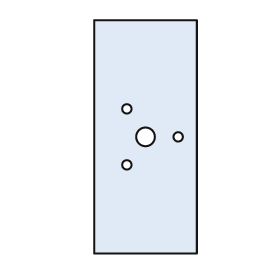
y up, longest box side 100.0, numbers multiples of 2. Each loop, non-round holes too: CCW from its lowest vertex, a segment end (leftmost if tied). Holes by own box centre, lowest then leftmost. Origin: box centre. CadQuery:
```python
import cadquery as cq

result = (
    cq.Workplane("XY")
    .moveTo(-22.0, -50.0)
    .lineTo(22.0, -50.0)
    .lineTo(22.0, 50.0)
    .lineTo(-22.0, 50.0)
    .close()
    .moveTo(-8.0, -12.0)
    .circle(2.0)
    .moveTo(0.0, 0.0)
    .circle(4.0)
    .moveTo(14.0, 0.0)
    .circle(2.0)
    .moveTo(-8.0, 12.0)
    .circle(2.0)
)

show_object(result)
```